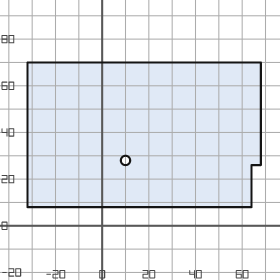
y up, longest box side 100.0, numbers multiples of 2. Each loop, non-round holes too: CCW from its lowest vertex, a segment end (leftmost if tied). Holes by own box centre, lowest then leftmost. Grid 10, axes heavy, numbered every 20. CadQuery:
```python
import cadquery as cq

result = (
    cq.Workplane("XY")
    .moveTo(-32.0, 8.0)
    .lineTo(64.0, 8.0)
    .lineTo(64.0, 26.0)
    .lineTo(68.0, 26.0)
    .lineTo(68.0, 70.0)
    .lineTo(-32.0, 70.0)
    .close()
    .moveTo(10.0, 28.0)
    .circle(2.0)
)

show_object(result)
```